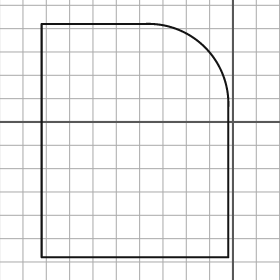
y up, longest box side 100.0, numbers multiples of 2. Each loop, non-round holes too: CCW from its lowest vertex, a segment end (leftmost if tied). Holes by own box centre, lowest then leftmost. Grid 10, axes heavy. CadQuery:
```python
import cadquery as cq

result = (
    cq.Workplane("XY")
    .moveTo(-82.0, -58.0)
    .lineTo(-2.0, -58.0)
    .lineTo(-2.0, 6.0)
    .threePointArc((-12.0, 32.0), (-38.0, 42.0))
    .lineTo(-82.0, 42.0)
    .close()
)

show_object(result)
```